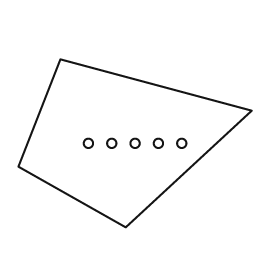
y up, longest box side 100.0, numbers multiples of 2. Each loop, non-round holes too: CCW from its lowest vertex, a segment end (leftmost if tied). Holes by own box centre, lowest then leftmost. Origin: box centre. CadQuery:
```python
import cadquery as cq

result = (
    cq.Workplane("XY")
    .moveTo(-4.0, -36.0)
    .lineTo(50.0, 14.0)
    .lineTo(-32.0, 36.0)
    .lineTo(-50.0, -10.0)
    .close()
    .moveTo(-20.0, 0.0)
    .circle(2.0)
    .moveTo(-10.0, 0.0)
    .circle(2.0)
    .moveTo(0.0, 0.0)
    .circle(2.0)
    .moveTo(10.0, 0.0)
    .circle(2.0)
    .moveTo(20.0, 0.0)
    .circle(2.0)
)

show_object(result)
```